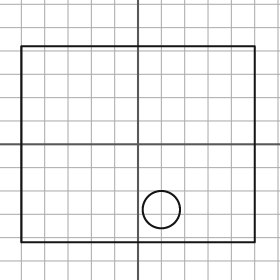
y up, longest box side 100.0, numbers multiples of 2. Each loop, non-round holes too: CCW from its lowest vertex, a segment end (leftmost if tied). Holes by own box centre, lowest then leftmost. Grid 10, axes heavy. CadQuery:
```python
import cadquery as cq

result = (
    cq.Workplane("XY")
    .moveTo(-50.0, -42.0)
    .lineTo(50.0, -42.0)
    .lineTo(50.0, 42.0)
    .lineTo(-50.0, 42.0)
    .close()
    .moveTo(10.0, -28.0)
    .circle(8.0)
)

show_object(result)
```